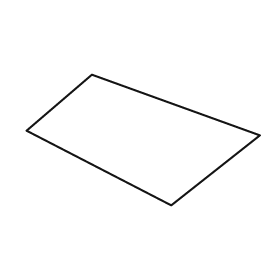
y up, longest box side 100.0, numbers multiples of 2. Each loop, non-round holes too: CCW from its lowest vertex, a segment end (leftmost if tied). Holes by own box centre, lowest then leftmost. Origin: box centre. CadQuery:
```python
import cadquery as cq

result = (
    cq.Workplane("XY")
    .moveTo(12.0, -28.0)
    .lineTo(50.0, 2.0)
    .lineTo(-22.0, 28.0)
    .lineTo(-50.0, 4.0)
    .close()
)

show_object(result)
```